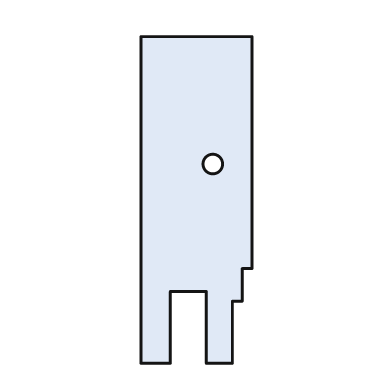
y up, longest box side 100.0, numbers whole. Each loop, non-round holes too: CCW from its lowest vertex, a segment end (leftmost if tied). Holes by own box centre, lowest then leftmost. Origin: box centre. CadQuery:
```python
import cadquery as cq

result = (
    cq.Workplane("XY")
    .moveTo(-17.0, -50.0)
    .lineTo(-8.0, -50.0)
    .lineTo(-8.0, -28.0)
    .lineTo(3.0, -28.0)
    .lineTo(3.0, -50.0)
    .lineTo(11.0, -50.0)
    .lineTo(11.0, -31.0)
    .lineTo(14.0, -31.0)
    .lineTo(14.0, -21.0)
    .lineTo(17.0, -21.0)
    .lineTo(17.0, 50.0)
    .lineTo(-17.0, 50.0)
    .close()
    .moveTo(5.0, 11.0)
    .circle(3.0)
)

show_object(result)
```